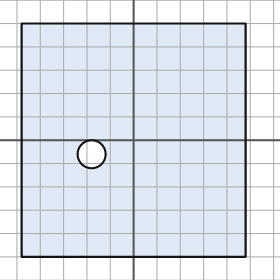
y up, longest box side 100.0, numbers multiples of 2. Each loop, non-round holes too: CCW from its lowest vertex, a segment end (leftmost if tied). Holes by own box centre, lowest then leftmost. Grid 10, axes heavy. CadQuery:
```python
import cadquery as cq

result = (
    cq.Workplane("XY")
    .moveTo(-48.0, -50.0)
    .lineTo(48.0, -50.0)
    .lineTo(48.0, 50.0)
    .lineTo(-48.0, 50.0)
    .close()
    .moveTo(-18.0, -6.0)
    .circle(6.0)
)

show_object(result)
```